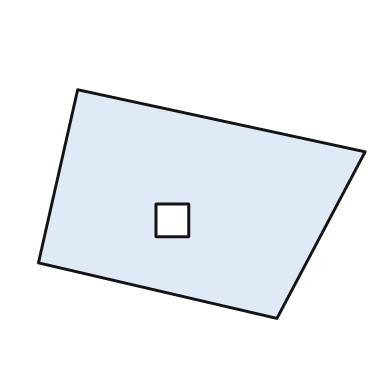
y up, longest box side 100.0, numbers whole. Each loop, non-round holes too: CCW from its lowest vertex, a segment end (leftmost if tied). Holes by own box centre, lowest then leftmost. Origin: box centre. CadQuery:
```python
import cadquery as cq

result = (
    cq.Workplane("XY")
    .moveTo(23.0, -35.0)
    .lineTo(50.0, 16.0)
    .lineTo(-38.0, 35.0)
    .lineTo(-50.0, -18.0)
    .close()
    .moveTo(-14.0, -10.0)
    .lineTo(-4.0, -10.0)
    .lineTo(-4.0, 0.0)
    .lineTo(-14.0, 0.0)
    .close()
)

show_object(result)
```